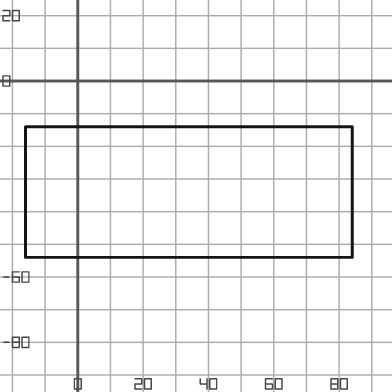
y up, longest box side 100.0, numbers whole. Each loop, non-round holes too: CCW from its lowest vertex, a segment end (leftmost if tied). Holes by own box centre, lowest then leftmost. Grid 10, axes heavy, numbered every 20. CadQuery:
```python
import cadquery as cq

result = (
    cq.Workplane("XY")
    .moveTo(-16.0, -54.0)
    .lineTo(84.0, -54.0)
    .lineTo(84.0, -14.0)
    .lineTo(-16.0, -14.0)
    .close()
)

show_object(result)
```